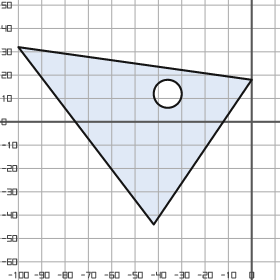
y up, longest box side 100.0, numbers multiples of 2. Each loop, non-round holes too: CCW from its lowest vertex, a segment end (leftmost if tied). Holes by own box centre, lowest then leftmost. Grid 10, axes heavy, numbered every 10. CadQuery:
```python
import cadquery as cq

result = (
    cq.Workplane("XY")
    .moveTo(-42.0, -44.0)
    .lineTo(0.0, 18.0)
    .lineTo(-100.0, 32.0)
    .close()
    .moveTo(-36.0, 12.0)
    .circle(6.0)
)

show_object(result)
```